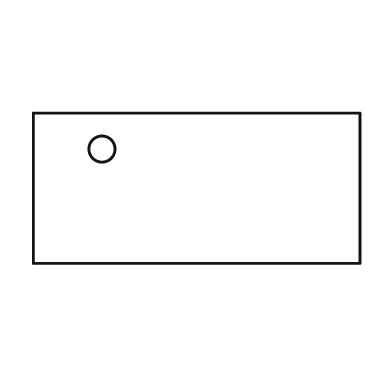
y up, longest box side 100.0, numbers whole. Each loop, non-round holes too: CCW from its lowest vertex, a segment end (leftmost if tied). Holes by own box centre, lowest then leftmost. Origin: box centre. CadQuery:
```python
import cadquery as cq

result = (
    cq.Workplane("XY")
    .moveTo(-50.0, -23.0)
    .lineTo(50.0, -23.0)
    .lineTo(50.0, 23.0)
    .lineTo(-50.0, 23.0)
    .close()
    .moveTo(-29.0, 12.0)
    .circle(4.0)
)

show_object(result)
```